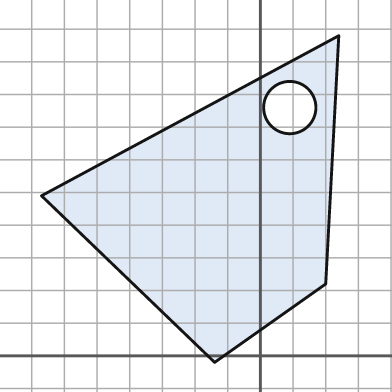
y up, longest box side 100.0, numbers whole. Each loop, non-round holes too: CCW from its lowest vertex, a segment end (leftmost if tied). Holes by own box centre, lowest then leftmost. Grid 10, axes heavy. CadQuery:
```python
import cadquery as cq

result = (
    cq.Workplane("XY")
    .moveTo(-14.0, -2.0)
    .lineTo(20.0, 22.0)
    .lineTo(24.0, 98.0)
    .lineTo(-67.0, 49.0)
    .close()
    .moveTo(9.0, 76.0)
    .circle(8.0)
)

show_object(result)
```